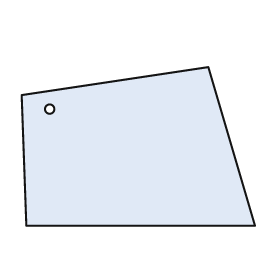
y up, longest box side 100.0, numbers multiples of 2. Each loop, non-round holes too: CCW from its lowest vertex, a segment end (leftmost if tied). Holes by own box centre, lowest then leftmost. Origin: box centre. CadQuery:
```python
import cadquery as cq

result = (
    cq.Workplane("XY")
    .moveTo(-48.0, -34.0)
    .lineTo(50.0, -34.0)
    .lineTo(30.0, 34.0)
    .lineTo(-50.0, 22.0)
    .close()
    .moveTo(-38.0, 16.0)
    .circle(2.0)
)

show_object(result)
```